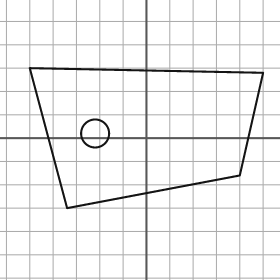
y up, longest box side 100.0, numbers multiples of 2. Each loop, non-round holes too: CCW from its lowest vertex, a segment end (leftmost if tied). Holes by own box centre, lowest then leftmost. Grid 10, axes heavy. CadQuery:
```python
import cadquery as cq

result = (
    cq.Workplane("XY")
    .moveTo(-34.0, -30.0)
    .lineTo(40.0, -16.0)
    .lineTo(50.0, 28.0)
    .lineTo(-50.0, 30.0)
    .close()
    .moveTo(-22.0, 2.0)
    .circle(6.0)
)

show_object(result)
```